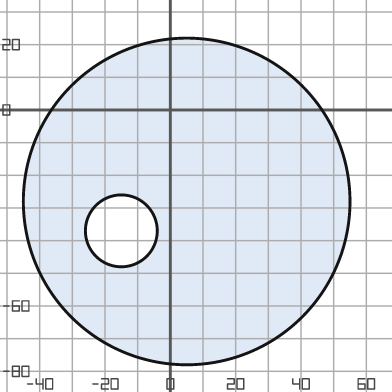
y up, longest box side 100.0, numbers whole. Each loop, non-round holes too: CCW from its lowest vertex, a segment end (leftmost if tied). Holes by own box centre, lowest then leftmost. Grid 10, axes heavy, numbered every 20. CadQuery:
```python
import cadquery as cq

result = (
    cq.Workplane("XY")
    .moveTo(5.0, -28.0)
    .circle(50.0)
    .moveTo(-15.0, -37.0)
    .circle(11.0)
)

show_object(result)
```